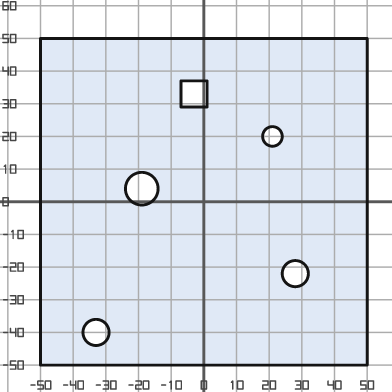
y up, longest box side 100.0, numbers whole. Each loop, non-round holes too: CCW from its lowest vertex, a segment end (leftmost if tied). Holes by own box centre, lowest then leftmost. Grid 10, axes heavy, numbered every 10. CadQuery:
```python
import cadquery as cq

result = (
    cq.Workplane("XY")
    .moveTo(-50.0, -50.0)
    .lineTo(50.0, -50.0)
    .lineTo(50.0, 50.0)
    .lineTo(-50.0, 50.0)
    .close()
    .moveTo(-33.0, -40.0)
    .circle(4.0)
    .moveTo(28.0, -22.0)
    .circle(4.0)
    .moveTo(-19.0, 4.0)
    .circle(5.0)
    .moveTo(21.0, 20.0)
    .circle(3.0)
    .moveTo(-7.0, 29.0)
    .lineTo(1.0, 29.0)
    .lineTo(1.0, 37.0)
    .lineTo(-7.0, 37.0)
    .close()
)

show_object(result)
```